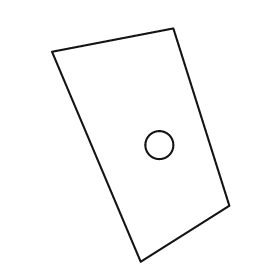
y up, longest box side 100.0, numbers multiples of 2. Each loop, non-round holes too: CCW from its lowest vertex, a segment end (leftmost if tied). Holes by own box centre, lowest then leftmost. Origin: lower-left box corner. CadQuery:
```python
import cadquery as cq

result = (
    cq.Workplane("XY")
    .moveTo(38.0, 0.0)
    .lineTo(76.0, 24.0)
    .lineTo(52.0, 100.0)
    .lineTo(0.0, 90.0)
    .close()
    .moveTo(46.0, 50.0)
    .circle(6.0)
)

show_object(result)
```